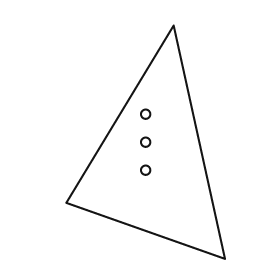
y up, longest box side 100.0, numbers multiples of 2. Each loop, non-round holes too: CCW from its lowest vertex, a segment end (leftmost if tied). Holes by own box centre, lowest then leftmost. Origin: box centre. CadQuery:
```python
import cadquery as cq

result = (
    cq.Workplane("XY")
    .moveTo(34.0, -50.0)
    .lineTo(12.0, 50.0)
    .lineTo(-34.0, -26.0)
    .close()
    .moveTo(0.0, -12.0)
    .circle(2.0)
    .moveTo(0.0, 0.0)
    .circle(2.0)
    .moveTo(0.0, 12.0)
    .circle(2.0)
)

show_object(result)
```